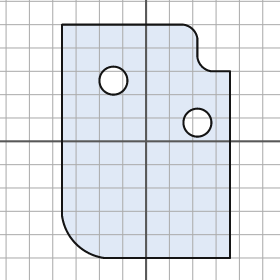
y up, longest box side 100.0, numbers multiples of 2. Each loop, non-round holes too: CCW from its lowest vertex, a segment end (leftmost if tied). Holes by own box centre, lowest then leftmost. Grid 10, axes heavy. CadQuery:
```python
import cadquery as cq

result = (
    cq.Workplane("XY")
    .moveTo(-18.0, -50.0)
    .lineTo(36.0, -50.0)
    .lineTo(36.0, 30.0)
    .lineTo(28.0, 30.0)
    .threePointArc((24.0, 32.0), (22.0, 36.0))
    .lineTo(22.0, 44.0)
    .threePointArc((20.0, 48.0), (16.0, 50.0))
    .lineTo(-36.0, 50.0)
    .lineTo(-36.0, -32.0)
    .threePointArc((-30.0, -44.0), (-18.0, -50.0))
    .close()
    .moveTo(22.0, 8.0)
    .circle(6.0)
    .moveTo(-14.0, 26.0)
    .circle(6.0)
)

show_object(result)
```